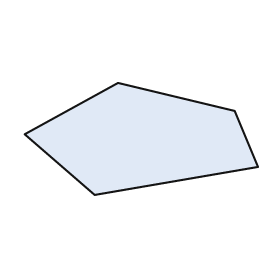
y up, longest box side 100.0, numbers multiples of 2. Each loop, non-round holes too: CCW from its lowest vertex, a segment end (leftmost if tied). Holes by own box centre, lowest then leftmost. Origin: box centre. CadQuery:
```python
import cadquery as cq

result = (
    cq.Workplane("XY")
    .moveTo(-20.0, -24.0)
    .lineTo(50.0, -12.0)
    .lineTo(40.0, 12.0)
    .lineTo(-10.0, 24.0)
    .lineTo(-50.0, 2.0)
    .close()
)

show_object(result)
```